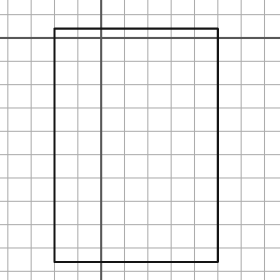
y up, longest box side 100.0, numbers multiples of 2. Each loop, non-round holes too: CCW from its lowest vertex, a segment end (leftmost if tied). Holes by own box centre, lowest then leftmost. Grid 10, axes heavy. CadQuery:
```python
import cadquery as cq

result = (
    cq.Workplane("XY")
    .moveTo(-20.0, -96.0)
    .lineTo(50.0, -96.0)
    .lineTo(50.0, 4.0)
    .lineTo(-20.0, 4.0)
    .close()
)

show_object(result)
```